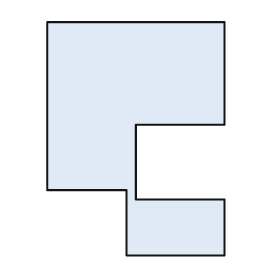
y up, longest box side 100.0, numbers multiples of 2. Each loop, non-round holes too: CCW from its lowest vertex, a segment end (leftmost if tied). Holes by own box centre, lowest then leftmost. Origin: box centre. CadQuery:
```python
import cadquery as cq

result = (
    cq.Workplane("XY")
    .moveTo(-4.0, -50.0)
    .lineTo(38.0, -50.0)
    .lineTo(38.0, -26.0)
    .lineTo(0.0, -26.0)
    .lineTo(0.0, 6.0)
    .lineTo(38.0, 6.0)
    .lineTo(38.0, 50.0)
    .lineTo(-38.0, 50.0)
    .lineTo(-38.0, -22.0)
    .lineTo(-4.0, -22.0)
    .close()
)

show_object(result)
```